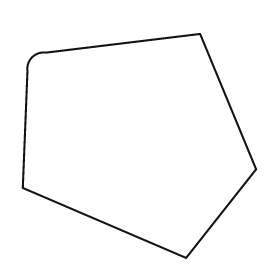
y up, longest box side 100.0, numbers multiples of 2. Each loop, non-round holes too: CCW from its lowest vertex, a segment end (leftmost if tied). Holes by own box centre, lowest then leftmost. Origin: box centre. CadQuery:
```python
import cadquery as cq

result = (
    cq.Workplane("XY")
    .moveTo(20.0, -48.0)
    .lineTo(50.0, -10.0)
    .lineTo(26.0, 48.0)
    .lineTo(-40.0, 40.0)
    .threePointArc((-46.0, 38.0), (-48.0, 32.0))
    .lineTo(-50.0, -18.0)
    .close()
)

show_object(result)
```